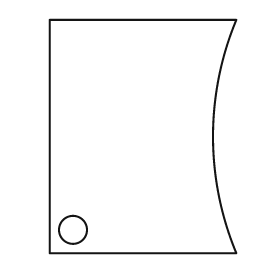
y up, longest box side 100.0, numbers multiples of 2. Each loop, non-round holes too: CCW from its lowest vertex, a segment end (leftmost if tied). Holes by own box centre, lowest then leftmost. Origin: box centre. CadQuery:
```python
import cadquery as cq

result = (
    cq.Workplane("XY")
    .moveTo(-40.0, -50.0)
    .lineTo(40.0, -50.0)
    .threePointArc((30.0, 0.0), (40.0, 50.0))
    .lineTo(-40.0, 50.0)
    .close()
    .moveTo(-30.0, -40.0)
    .circle(6.0)
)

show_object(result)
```